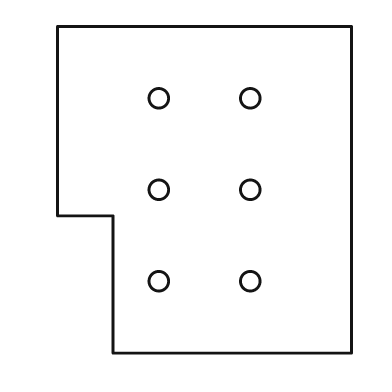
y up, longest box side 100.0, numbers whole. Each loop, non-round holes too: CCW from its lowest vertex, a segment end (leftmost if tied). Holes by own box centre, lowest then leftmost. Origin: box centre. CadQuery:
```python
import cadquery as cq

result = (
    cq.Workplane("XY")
    .moveTo(-28.0, -50.0)
    .lineTo(45.0, -50.0)
    .lineTo(45.0, 50.0)
    .lineTo(-45.0, 50.0)
    .lineTo(-45.0, -8.0)
    .lineTo(-28.0, -8.0)
    .close()
    .moveTo(-14.0, -28.0)
    .circle(3.0)
    .moveTo(14.0, -28.0)
    .circle(3.0)
    .moveTo(-14.0, 0.0)
    .circle(3.0)
    .moveTo(14.0, 0.0)
    .circle(3.0)
    .moveTo(-14.0, 28.0)
    .circle(3.0)
    .moveTo(14.0, 28.0)
    .circle(3.0)
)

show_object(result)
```